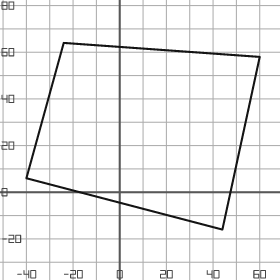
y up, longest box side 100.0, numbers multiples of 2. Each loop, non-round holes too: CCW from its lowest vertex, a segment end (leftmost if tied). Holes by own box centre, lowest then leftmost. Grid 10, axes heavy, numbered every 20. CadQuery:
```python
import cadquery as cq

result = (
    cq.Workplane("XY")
    .moveTo(44.0, -16.0)
    .lineTo(60.0, 58.0)
    .lineTo(-24.0, 64.0)
    .lineTo(-40.0, 6.0)
    .close()
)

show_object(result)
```